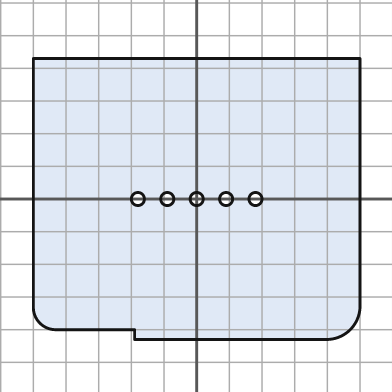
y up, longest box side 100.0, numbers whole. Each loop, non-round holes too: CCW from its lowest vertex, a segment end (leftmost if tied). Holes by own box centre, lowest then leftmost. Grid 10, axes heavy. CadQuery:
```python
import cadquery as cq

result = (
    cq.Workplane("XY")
    .moveTo(-19.0, -43.0)
    .lineTo(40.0, -43.0)
    .threePointArc((47.0, -40.0), (50.0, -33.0))
    .lineTo(50.0, 43.0)
    .lineTo(-50.0, 43.0)
    .lineTo(-50.0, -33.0)
    .threePointArc((-48.0, -38.0), (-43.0, -40.0))
    .lineTo(-19.0, -40.0)
    .close()
    .moveTo(-18.0, 0.0)
    .circle(2.0)
    .moveTo(-9.0, 0.0)
    .circle(2.0)
    .moveTo(0.0, 0.0)
    .circle(2.0)
    .moveTo(9.0, 0.0)
    .circle(2.0)
    .moveTo(18.0, 0.0)
    .circle(2.0)
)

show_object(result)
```